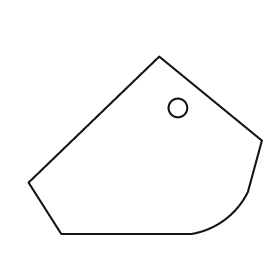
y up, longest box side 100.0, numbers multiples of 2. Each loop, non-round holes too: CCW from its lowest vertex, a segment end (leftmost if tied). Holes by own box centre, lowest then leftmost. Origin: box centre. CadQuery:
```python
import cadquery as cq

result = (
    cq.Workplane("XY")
    .moveTo(-36.0, -38.0)
    .lineTo(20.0, -38.0)
    .threePointArc((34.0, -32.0), (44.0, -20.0))
    .lineTo(50.0, 2.0)
    .lineTo(6.0, 38.0)
    .lineTo(-50.0, -16.0)
    .close()
    .moveTo(14.0, 16.0)
    .circle(4.0)
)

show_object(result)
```